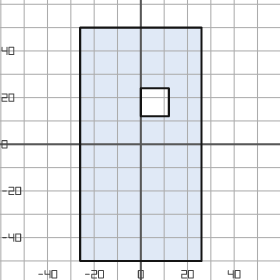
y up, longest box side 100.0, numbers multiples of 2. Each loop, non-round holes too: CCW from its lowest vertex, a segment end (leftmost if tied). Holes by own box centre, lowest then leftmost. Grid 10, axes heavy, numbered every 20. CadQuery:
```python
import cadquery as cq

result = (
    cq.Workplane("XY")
    .moveTo(-26.0, -50.0)
    .lineTo(26.0, -50.0)
    .lineTo(26.0, 50.0)
    .lineTo(-26.0, 50.0)
    .close()
    .moveTo(0.0, 12.0)
    .lineTo(12.0, 12.0)
    .lineTo(12.0, 24.0)
    .lineTo(0.0, 24.0)
    .close()
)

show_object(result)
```